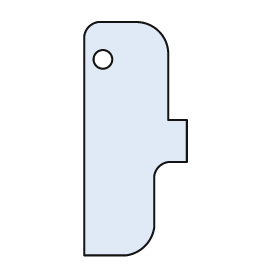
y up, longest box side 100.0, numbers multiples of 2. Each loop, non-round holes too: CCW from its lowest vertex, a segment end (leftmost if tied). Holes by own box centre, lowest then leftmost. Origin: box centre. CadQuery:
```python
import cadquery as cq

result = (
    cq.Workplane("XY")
    .moveTo(-22.0, -50.0)
    .lineTo(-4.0, -50.0)
    .threePointArc((4.0, -46.0), (8.0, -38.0))
    .lineTo(8.0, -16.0)
    .threePointArc((10.0, -12.0), (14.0, -10.0))
    .lineTo(22.0, -10.0)
    .lineTo(22.0, 8.0)
    .lineTo(14.0, 8.0)
    .lineTo(14.0, 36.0)
    .threePointArc((10.0, 46.0), (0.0, 50.0))
    .lineTo(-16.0, 50.0)
    .threePointArc((-20.0, 48.0), (-22.0, 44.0))
    .close()
    .moveTo(-14.0, 34.0)
    .circle(4.0)
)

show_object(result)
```